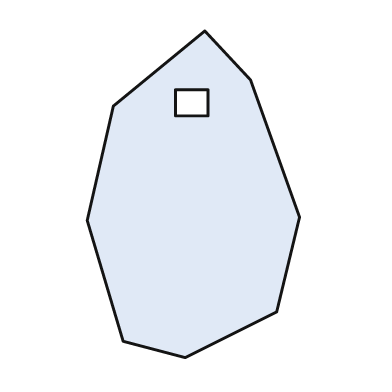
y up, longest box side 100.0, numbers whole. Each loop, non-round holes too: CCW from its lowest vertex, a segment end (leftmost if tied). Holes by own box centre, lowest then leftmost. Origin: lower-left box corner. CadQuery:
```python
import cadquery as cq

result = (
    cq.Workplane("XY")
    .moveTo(30.0, 0.0)
    .lineTo(58.0, 14.0)
    .lineTo(65.0, 43.0)
    .lineTo(50.0, 85.0)
    .lineTo(36.0, 100.0)
    .lineTo(8.0, 77.0)
    .lineTo(0.0, 42.0)
    .lineTo(11.0, 5.0)
    .close()
    .moveTo(27.0, 74.0)
    .lineTo(37.0, 74.0)
    .lineTo(37.0, 82.0)
    .lineTo(27.0, 82.0)
    .close()
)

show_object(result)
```